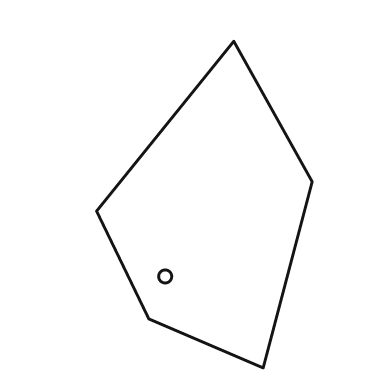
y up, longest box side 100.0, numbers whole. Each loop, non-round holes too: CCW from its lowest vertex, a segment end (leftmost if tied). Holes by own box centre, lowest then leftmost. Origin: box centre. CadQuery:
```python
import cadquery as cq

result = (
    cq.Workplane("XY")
    .moveTo(18.0, -50.0)
    .lineTo(33.0, 7.0)
    .lineTo(9.0, 50.0)
    .lineTo(-33.0, -2.0)
    .lineTo(-17.0, -35.0)
    .close()
    .moveTo(-12.0, -22.0)
    .circle(2.0)
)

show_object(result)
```